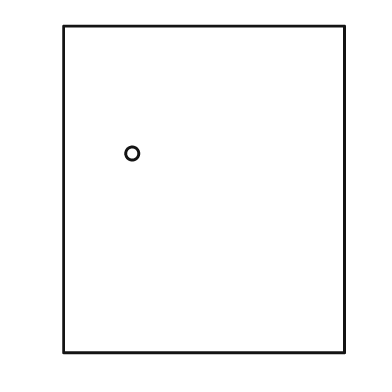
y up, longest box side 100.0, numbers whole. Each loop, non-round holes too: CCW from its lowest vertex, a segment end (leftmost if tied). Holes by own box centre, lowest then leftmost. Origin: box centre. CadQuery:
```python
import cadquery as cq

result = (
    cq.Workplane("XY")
    .moveTo(-43.0, -50.0)
    .lineTo(43.0, -50.0)
    .lineTo(43.0, 50.0)
    .lineTo(-43.0, 50.0)
    .close()
    .moveTo(-22.0, 11.0)
    .circle(2.0)
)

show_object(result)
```